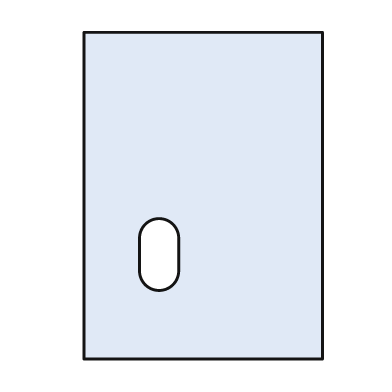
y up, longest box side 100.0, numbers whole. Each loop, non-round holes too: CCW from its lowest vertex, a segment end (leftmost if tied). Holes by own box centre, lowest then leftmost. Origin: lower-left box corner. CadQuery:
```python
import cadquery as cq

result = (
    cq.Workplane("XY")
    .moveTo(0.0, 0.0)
    .lineTo(73.0, 0.0)
    .lineTo(73.0, 100.0)
    .lineTo(0.0, 100.0)
    .close()
    .moveTo(17.0, 27.0)
    .threePointArc((23.0, 21.0), (29.0, 27.0))
    .lineTo(29.0, 37.0)
    .threePointArc((23.0, 43.0), (17.0, 37.0))
    .close()
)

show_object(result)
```